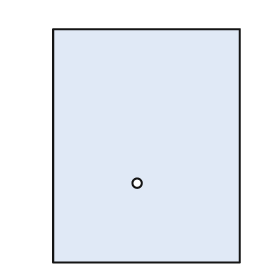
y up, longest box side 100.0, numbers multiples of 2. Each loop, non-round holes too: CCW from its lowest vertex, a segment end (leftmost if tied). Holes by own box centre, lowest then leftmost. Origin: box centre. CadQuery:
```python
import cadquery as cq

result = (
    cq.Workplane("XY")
    .moveTo(-40.0, -50.0)
    .lineTo(40.0, -50.0)
    .lineTo(40.0, 50.0)
    .lineTo(-40.0, 50.0)
    .close()
    .moveTo(-4.0, -16.0)
    .circle(2.0)
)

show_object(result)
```